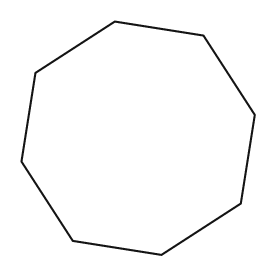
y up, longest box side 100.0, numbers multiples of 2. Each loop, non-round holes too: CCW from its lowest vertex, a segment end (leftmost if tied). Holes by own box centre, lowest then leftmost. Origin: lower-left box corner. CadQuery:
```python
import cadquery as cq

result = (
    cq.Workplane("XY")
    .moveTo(60.0, 0.0)
    .lineTo(94.0, 22.0)
    .lineTo(100.0, 60.0)
    .lineTo(78.0, 94.0)
    .lineTo(40.0, 100.0)
    .lineTo(6.0, 78.0)
    .lineTo(0.0, 40.0)
    .lineTo(22.0, 6.0)
    .close()
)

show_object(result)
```